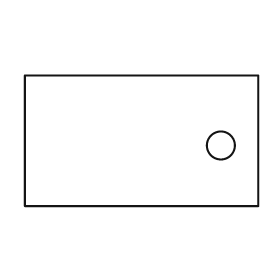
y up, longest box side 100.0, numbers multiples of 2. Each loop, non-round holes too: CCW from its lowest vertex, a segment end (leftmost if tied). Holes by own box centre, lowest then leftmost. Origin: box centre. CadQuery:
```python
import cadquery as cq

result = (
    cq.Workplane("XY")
    .moveTo(-50.0, -28.0)
    .lineTo(50.0, -28.0)
    .lineTo(50.0, 28.0)
    .lineTo(-50.0, 28.0)
    .close()
    .moveTo(34.0, -2.0)
    .circle(6.0)
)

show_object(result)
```